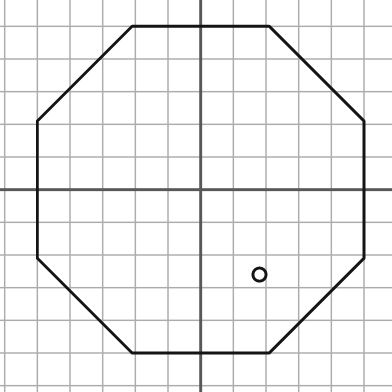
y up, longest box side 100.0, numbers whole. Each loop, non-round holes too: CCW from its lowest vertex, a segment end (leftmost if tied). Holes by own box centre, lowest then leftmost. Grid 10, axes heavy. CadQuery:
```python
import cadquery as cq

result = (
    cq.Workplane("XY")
    .moveTo(-21.0, -50.0)
    .lineTo(21.0, -50.0)
    .lineTo(50.0, -21.0)
    .lineTo(50.0, 21.0)
    .lineTo(21.0, 50.0)
    .lineTo(-21.0, 50.0)
    .lineTo(-50.0, 21.0)
    .lineTo(-50.0, -21.0)
    .close()
    .moveTo(18.0, -26.0)
    .circle(2.0)
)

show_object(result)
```